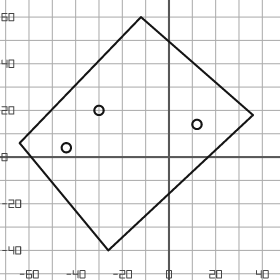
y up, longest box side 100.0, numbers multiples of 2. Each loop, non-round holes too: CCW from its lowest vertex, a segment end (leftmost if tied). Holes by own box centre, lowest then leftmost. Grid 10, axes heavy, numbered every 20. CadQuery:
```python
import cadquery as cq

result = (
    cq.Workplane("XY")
    .moveTo(-26.0, -40.0)
    .lineTo(36.0, 18.0)
    .lineTo(-12.0, 60.0)
    .lineTo(-64.0, 6.0)
    .close()
    .moveTo(-44.0, 4.0)
    .circle(2.0)
    .moveTo(12.0, 14.0)
    .circle(2.0)
    .moveTo(-30.0, 20.0)
    .circle(2.0)
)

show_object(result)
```